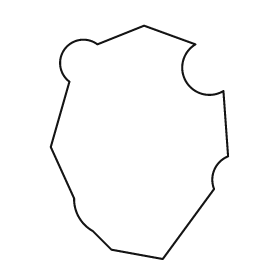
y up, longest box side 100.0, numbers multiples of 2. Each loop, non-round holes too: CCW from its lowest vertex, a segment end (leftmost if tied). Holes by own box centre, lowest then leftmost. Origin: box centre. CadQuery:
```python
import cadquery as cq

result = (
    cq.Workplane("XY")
    .moveTo(10.0, -50.0)
    .lineTo(32.0, -20.0)
    .threePointArc((32.0, -12.0), (38.0, -6.0))
    .lineTo(36.0, 22.0)
    .threePointArc((20.0, 26.0), (24.0, 42.0))
    .lineTo(2.0, 50.0)
    .lineTo(-18.0, 42.0)
    .threePointArc((-32.0, 40.0), (-30.0, 26.0))
    .lineTo(-38.0, -2.0)
    .lineTo(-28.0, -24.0)
    .threePointArc((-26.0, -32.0), (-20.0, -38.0))
    .lineTo(-12.0, -46.0)
    .close()
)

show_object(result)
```